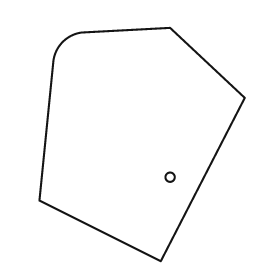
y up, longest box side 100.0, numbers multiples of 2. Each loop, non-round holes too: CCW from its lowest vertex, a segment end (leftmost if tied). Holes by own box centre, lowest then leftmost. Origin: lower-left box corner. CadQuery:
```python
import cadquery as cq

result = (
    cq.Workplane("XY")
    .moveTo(52.0, 0.0)
    .lineTo(88.0, 70.0)
    .lineTo(56.0, 100.0)
    .lineTo(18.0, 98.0)
    .threePointArc((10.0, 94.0), (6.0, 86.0))
    .lineTo(0.0, 26.0)
    .close()
    .moveTo(56.0, 36.0)
    .circle(2.0)
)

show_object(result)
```